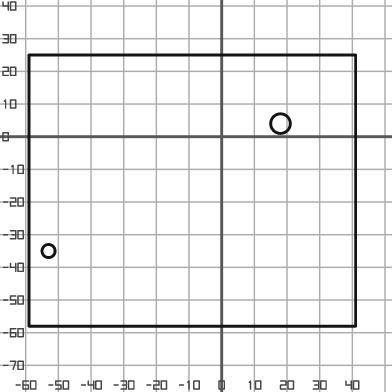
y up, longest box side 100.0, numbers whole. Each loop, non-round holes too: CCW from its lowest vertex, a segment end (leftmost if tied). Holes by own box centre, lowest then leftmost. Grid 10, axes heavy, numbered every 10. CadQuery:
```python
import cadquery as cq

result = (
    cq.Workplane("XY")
    .moveTo(-59.0, -58.0)
    .lineTo(41.0, -58.0)
    .lineTo(41.0, 25.0)
    .lineTo(-59.0, 25.0)
    .close()
    .moveTo(-53.0, -35.0)
    .circle(2.0)
    .moveTo(18.0, 4.0)
    .circle(3.0)
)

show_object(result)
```